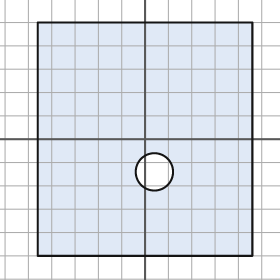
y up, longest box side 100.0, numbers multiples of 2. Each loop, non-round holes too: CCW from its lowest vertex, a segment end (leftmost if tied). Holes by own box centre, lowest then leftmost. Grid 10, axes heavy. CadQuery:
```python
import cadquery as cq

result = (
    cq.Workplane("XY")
    .moveTo(-46.0, -50.0)
    .lineTo(46.0, -50.0)
    .lineTo(46.0, 50.0)
    .lineTo(-46.0, 50.0)
    .close()
    .moveTo(4.0, -14.0)
    .circle(8.0)
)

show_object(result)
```